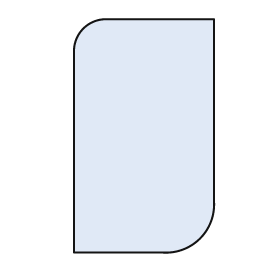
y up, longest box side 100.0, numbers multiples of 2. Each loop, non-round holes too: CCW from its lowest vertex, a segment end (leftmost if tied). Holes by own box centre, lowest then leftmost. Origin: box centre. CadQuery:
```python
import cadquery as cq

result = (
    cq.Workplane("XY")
    .moveTo(-30.0, -50.0)
    .lineTo(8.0, -50.0)
    .threePointArc((24.0, -44.0), (30.0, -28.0))
    .lineTo(30.0, 50.0)
    .lineTo(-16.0, 50.0)
    .threePointArc((-26.0, 46.0), (-30.0, 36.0))
    .close()
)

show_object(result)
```